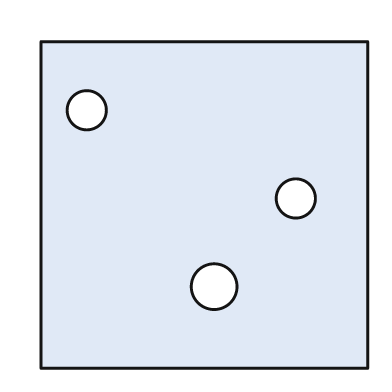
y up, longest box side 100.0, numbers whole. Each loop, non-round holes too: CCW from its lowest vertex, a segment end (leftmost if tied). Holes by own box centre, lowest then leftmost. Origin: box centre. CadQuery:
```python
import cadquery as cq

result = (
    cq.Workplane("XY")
    .moveTo(-50.0, -50.0)
    .lineTo(50.0, -50.0)
    .lineTo(50.0, 50.0)
    .lineTo(-50.0, 50.0)
    .close()
    .moveTo(3.0, -25.0)
    .circle(7.0)
    .moveTo(28.0, 2.0)
    .circle(6.0)
    .moveTo(-36.0, 29.0)
    .circle(6.0)
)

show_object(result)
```